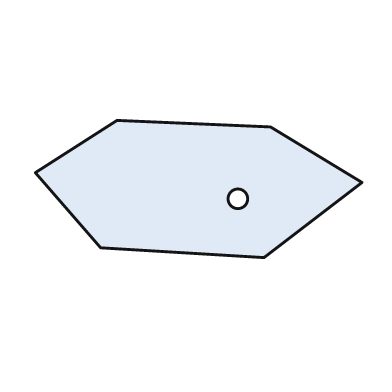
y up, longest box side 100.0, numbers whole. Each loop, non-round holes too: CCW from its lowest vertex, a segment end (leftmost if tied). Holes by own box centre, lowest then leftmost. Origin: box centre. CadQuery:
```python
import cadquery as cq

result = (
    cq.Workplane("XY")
    .moveTo(20.0, -21.0)
    .lineTo(50.0, 2.0)
    .lineTo(22.0, 19.0)
    .lineTo(-25.0, 21.0)
    .lineTo(-50.0, 5.0)
    .lineTo(-30.0, -18.0)
    .close()
    .moveTo(12.0, -3.0)
    .circle(3.0)
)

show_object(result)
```